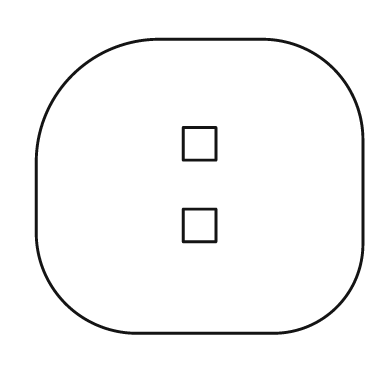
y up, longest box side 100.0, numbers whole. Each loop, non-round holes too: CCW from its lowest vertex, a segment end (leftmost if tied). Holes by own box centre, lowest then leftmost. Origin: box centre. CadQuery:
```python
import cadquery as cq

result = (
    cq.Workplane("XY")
    .moveTo(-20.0, -45.0)
    .lineTo(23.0, -45.0)
    .threePointArc((42.0, -37.0), (50.0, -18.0))
    .lineTo(50.0, 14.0)
    .threePointArc((41.0, 36.0), (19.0, 45.0))
    .lineTo(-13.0, 45.0)
    .threePointArc((-39.0, 34.0), (-50.0, 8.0))
    .lineTo(-50.0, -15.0)
    .threePointArc((-41.0, -36.0), (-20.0, -45.0))
    .close()
    .moveTo(-5.0, -17.0)
    .lineTo(5.0, -17.0)
    .lineTo(5.0, -7.0)
    .lineTo(-5.0, -7.0)
    .close()
    .moveTo(-5.0, 8.0)
    .lineTo(5.0, 8.0)
    .lineTo(5.0, 18.0)
    .lineTo(-5.0, 18.0)
    .close()
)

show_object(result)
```